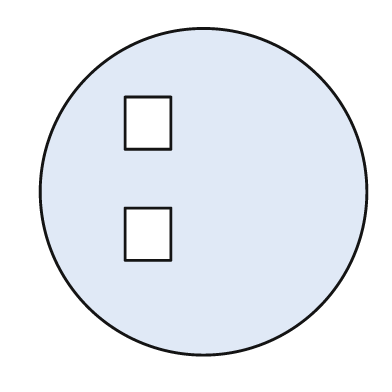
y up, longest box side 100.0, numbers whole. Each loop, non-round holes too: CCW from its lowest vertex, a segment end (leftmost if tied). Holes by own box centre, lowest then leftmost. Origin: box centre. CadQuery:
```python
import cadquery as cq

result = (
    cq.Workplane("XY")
    .moveTo(0.0, 0.0)
    .circle(50.0)
    .moveTo(-24.0, -21.0)
    .lineTo(-10.0, -21.0)
    .lineTo(-10.0, -5.0)
    .lineTo(-24.0, -5.0)
    .close()
    .moveTo(-24.0, 13.0)
    .lineTo(-10.0, 13.0)
    .lineTo(-10.0, 29.0)
    .lineTo(-24.0, 29.0)
    .close()
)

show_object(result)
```